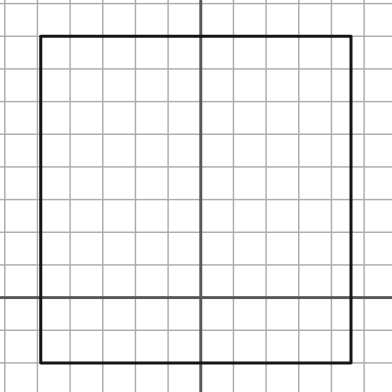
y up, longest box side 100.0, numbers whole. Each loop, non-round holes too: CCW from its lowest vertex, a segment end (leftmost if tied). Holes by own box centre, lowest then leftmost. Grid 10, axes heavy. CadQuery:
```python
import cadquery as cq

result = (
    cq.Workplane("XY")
    .moveTo(-49.0, -20.0)
    .lineTo(46.0, -20.0)
    .lineTo(46.0, 80.0)
    .lineTo(-49.0, 80.0)
    .close()
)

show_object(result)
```